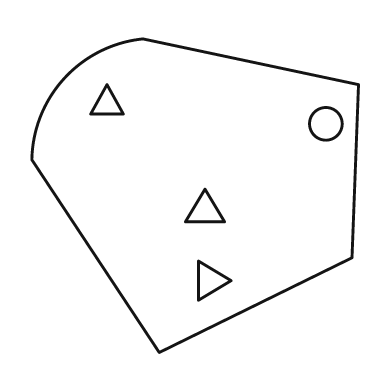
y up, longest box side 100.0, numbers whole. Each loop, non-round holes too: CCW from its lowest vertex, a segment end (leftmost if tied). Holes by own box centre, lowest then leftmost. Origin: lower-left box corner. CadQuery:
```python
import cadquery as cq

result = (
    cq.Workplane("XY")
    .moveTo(39.0, 0.0)
    .lineTo(98.0, 29.0)
    .lineTo(100.0, 82.0)
    .lineTo(34.0, 96.0)
    .threePointArc((10.0, 84.0), (0.0, 59.0))
    .close()
    .moveTo(51.0, 16.0)
    .lineTo(61.0, 22.0)
    .lineTo(51.0, 28.0)
    .close()
    .moveTo(47.0, 40.0)
    .lineTo(59.0, 40.0)
    .lineTo(53.0, 50.0)
    .close()
    .moveTo(90.0, 70.0)
    .circle(5.0)
    .moveTo(18.0, 73.0)
    .lineTo(28.0, 73.0)
    .lineTo(23.0, 82.0)
    .close()
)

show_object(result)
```